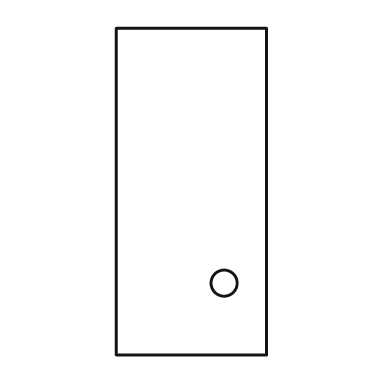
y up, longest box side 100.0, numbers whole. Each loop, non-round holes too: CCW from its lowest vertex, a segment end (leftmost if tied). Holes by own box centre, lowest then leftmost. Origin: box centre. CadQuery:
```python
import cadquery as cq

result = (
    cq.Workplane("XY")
    .moveTo(-23.0, -50.0)
    .lineTo(23.0, -50.0)
    .lineTo(23.0, 50.0)
    .lineTo(-23.0, 50.0)
    .close()
    .moveTo(10.0, -28.0)
    .circle(4.0)
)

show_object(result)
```